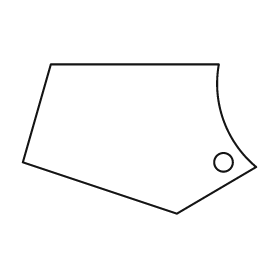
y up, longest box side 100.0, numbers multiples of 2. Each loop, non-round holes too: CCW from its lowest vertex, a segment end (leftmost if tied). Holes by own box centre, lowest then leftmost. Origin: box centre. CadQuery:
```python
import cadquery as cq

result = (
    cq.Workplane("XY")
    .moveTo(16.0, -32.0)
    .lineTo(50.0, -12.0)
    .threePointArc((36.0, 8.0), (34.0, 32.0))
    .lineTo(-38.0, 32.0)
    .lineTo(-50.0, -10.0)
    .close()
    .moveTo(36.0, -10.0)
    .circle(4.0)
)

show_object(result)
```